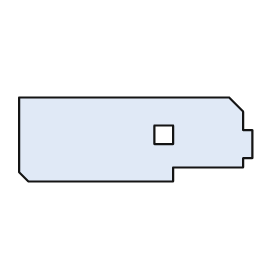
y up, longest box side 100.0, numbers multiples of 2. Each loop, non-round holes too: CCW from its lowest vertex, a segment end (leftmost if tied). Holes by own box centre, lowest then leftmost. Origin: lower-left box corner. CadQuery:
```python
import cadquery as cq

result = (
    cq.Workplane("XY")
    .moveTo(4.0, 0.0)
    .lineTo(66.0, 0.0)
    .lineTo(66.0, 6.0)
    .lineTo(96.0, 6.0)
    .lineTo(96.0, 10.0)
    .lineTo(100.0, 10.0)
    .lineTo(100.0, 22.0)
    .lineTo(96.0, 22.0)
    .lineTo(96.0, 30.0)
    .lineTo(90.0, 36.0)
    .lineTo(0.0, 36.0)
    .lineTo(0.0, 4.0)
    .close()
    .moveTo(58.0, 16.0)
    .lineTo(66.0, 16.0)
    .lineTo(66.0, 24.0)
    .lineTo(58.0, 24.0)
    .close()
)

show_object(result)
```